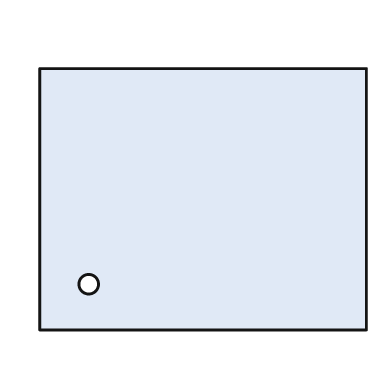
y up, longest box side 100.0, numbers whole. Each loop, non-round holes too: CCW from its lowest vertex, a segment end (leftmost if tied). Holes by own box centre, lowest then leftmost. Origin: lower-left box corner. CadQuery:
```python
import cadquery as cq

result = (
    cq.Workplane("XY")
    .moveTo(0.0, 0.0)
    .lineTo(100.0, 0.0)
    .lineTo(100.0, 80.0)
    .lineTo(0.0, 80.0)
    .close()
    .moveTo(15.0, 14.0)
    .circle(3.0)
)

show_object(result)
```